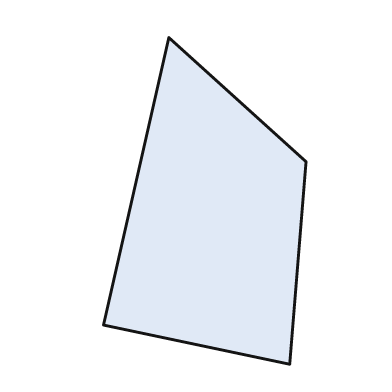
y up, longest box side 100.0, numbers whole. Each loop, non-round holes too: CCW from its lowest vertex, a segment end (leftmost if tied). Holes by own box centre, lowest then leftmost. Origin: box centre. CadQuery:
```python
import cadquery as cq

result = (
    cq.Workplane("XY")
    .moveTo(26.0, -50.0)
    .lineTo(31.0, 12.0)
    .lineTo(-11.0, 50.0)
    .lineTo(-31.0, -38.0)
    .close()
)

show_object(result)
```